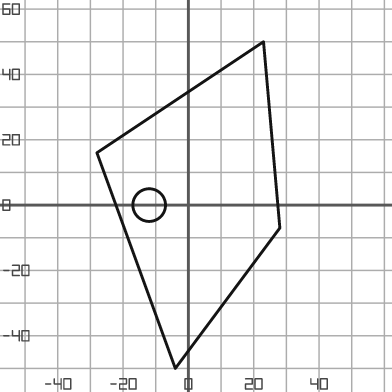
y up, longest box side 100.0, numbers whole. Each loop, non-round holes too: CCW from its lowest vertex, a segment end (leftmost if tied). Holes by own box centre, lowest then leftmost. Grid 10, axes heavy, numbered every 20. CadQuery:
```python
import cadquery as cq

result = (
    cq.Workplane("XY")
    .moveTo(-4.0, -50.0)
    .lineTo(28.0, -7.0)
    .lineTo(23.0, 50.0)
    .lineTo(-28.0, 16.0)
    .close()
    .moveTo(-12.0, 0.0)
    .circle(5.0)
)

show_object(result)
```